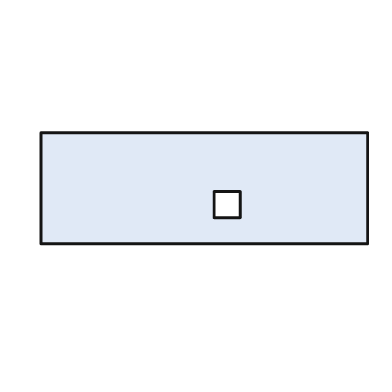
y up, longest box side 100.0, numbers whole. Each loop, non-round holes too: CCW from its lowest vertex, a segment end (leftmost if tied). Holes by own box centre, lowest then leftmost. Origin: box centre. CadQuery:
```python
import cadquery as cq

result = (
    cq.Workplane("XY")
    .moveTo(-50.0, -17.0)
    .lineTo(50.0, -17.0)
    .lineTo(50.0, 17.0)
    .lineTo(-50.0, 17.0)
    .close()
    .moveTo(3.0, -9.0)
    .lineTo(11.0, -9.0)
    .lineTo(11.0, -1.0)
    .lineTo(3.0, -1.0)
    .close()
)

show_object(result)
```